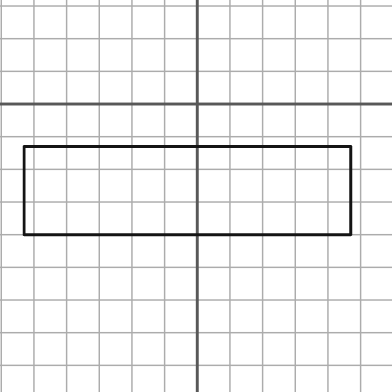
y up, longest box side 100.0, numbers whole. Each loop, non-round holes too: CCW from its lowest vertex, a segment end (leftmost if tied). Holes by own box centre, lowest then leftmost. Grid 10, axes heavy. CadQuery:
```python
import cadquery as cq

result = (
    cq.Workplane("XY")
    .moveTo(-53.0, -40.0)
    .lineTo(47.0, -40.0)
    .lineTo(47.0, -13.0)
    .lineTo(-53.0, -13.0)
    .close()
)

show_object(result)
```